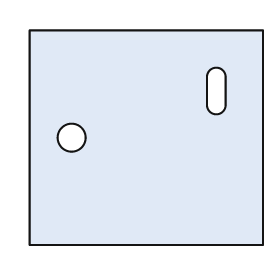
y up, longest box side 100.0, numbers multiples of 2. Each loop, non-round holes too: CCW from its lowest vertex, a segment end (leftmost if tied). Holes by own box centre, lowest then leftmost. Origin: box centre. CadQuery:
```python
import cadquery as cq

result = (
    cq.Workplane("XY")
    .moveTo(-50.0, -46.0)
    .lineTo(50.0, -46.0)
    .lineTo(50.0, 46.0)
    .lineTo(-50.0, 46.0)
    .close()
    .moveTo(-32.0, 0.0)
    .circle(6.0)
    .moveTo(26.0, 14.0)
    .threePointArc((30.0, 10.0), (34.0, 14.0))
    .lineTo(34.0, 26.0)
    .threePointArc((30.0, 30.0), (26.0, 26.0))
    .close()
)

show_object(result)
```